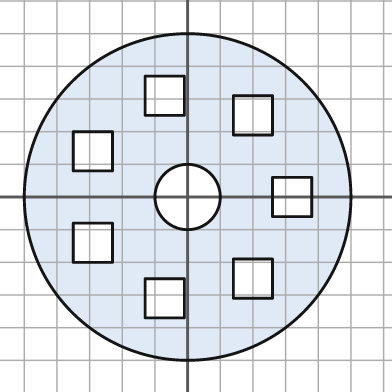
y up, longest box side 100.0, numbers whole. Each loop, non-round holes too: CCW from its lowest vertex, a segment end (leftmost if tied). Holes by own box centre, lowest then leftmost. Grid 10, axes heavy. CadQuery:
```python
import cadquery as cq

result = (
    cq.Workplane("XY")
    .moveTo(0.0, 0.0)
    .circle(50.0)
    .moveTo(-13.0, -37.0)
    .lineTo(-1.0, -37.0)
    .lineTo(-1.0, -25.0)
    .lineTo(-13.0, -25.0)
    .close()
    .moveTo(14.0, -31.0)
    .lineTo(26.0, -31.0)
    .lineTo(26.0, -19.0)
    .lineTo(14.0, -19.0)
    .close()
    .moveTo(-35.0, -20.0)
    .lineTo(-23.0, -20.0)
    .lineTo(-23.0, -8.0)
    .lineTo(-35.0, -8.0)
    .close()
    .moveTo(0.0, 0.0)
    .circle(10.0)
    .moveTo(26.0, -6.0)
    .lineTo(38.0, -6.0)
    .lineTo(38.0, 6.0)
    .lineTo(26.0, 6.0)
    .close()
    .moveTo(-35.0, 8.0)
    .lineTo(-23.0, 8.0)
    .lineTo(-23.0, 20.0)
    .lineTo(-35.0, 20.0)
    .close()
    .moveTo(14.0, 19.0)
    .lineTo(26.0, 19.0)
    .lineTo(26.0, 31.0)
    .lineTo(14.0, 31.0)
    .close()
    .moveTo(-13.0, 25.0)
    .lineTo(-1.0, 25.0)
    .lineTo(-1.0, 37.0)
    .lineTo(-13.0, 37.0)
    .close()
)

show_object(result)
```